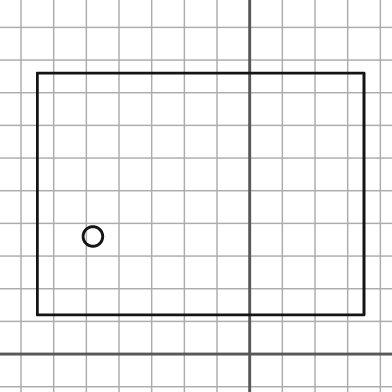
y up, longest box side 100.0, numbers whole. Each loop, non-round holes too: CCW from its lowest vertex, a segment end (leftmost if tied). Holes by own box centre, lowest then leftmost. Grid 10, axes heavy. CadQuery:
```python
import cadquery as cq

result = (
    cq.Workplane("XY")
    .moveTo(-65.0, 12.0)
    .lineTo(35.0, 12.0)
    .lineTo(35.0, 86.0)
    .lineTo(-65.0, 86.0)
    .close()
    .moveTo(-48.0, 36.0)
    .circle(3.0)
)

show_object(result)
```